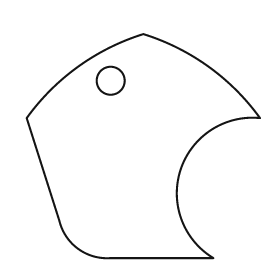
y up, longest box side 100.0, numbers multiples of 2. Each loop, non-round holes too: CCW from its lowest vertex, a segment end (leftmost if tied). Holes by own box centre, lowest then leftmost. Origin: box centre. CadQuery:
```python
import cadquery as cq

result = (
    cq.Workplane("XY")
    .moveTo(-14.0, -48.0)
    .lineTo(30.0, -48.0)
    .threePointArc((16.0, -10.0), (50.0, 12.0))
    .threePointArc((28.0, 34.0), (0.0, 48.0))
    .threePointArc((-28.0, 34.0), (-50.0, 12.0))
    .lineTo(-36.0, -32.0)
    .threePointArc((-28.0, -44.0), (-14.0, -48.0))
    .close()
    .moveTo(-14.0, 28.0)
    .circle(6.0)
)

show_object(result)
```